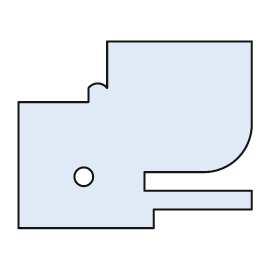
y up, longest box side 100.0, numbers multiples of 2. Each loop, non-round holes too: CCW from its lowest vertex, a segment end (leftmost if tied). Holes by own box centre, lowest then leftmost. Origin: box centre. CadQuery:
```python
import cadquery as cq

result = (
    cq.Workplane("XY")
    .moveTo(-50.0, -40.0)
    .lineTo(8.0, -40.0)
    .lineTo(8.0, -32.0)
    .lineTo(50.0, -32.0)
    .lineTo(50.0, -24.0)
    .lineTo(4.0, -24.0)
    .lineTo(4.0, -16.0)
    .lineTo(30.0, -16.0)
    .threePointArc((44.0, -10.0), (50.0, 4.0))
    .lineTo(50.0, 40.0)
    .lineTo(-12.0, 40.0)
    .lineTo(-12.0, 20.0)
    .threePointArc((-16.0, 22.0), (-20.0, 20.0))
    .lineTo(-20.0, 14.0)
    .lineTo(-50.0, 14.0)
    .close()
    .moveTo(-22.0, -18.0)
    .circle(4.0)
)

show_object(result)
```